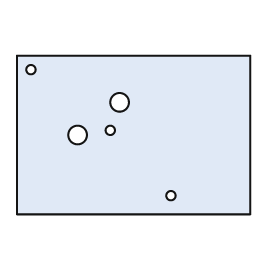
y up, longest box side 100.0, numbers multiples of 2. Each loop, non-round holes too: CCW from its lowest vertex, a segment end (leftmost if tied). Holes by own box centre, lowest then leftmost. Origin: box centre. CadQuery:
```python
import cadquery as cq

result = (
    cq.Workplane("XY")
    .moveTo(-50.0, -34.0)
    .lineTo(50.0, -34.0)
    .lineTo(50.0, 34.0)
    .lineTo(-50.0, 34.0)
    .close()
    .moveTo(16.0, -26.0)
    .circle(2.0)
    .moveTo(-24.0, 0.0)
    .circle(4.0)
    .moveTo(-10.0, 2.0)
    .circle(2.0)
    .moveTo(-6.0, 14.0)
    .circle(4.0)
    .moveTo(-44.0, 28.0)
    .circle(2.0)
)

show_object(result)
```